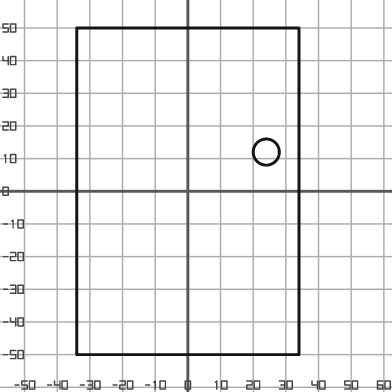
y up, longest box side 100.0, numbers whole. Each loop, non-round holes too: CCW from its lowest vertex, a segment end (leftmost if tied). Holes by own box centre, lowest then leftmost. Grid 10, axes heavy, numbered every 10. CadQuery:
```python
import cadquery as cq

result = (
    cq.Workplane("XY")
    .moveTo(-34.0, -50.0)
    .lineTo(34.0, -50.0)
    .lineTo(34.0, 50.0)
    .lineTo(-34.0, 50.0)
    .close()
    .moveTo(24.0, 12.0)
    .circle(4.0)
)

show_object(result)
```